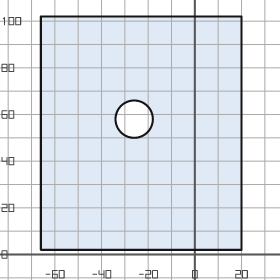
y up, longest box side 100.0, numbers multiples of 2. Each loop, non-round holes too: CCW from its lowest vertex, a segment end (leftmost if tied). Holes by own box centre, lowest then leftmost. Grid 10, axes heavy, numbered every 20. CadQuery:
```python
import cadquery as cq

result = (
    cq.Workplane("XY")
    .moveTo(-66.0, 2.0)
    .lineTo(20.0, 2.0)
    .lineTo(20.0, 102.0)
    .lineTo(-66.0, 102.0)
    .close()
    .moveTo(-26.0, 58.0)
    .circle(8.0)
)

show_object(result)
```